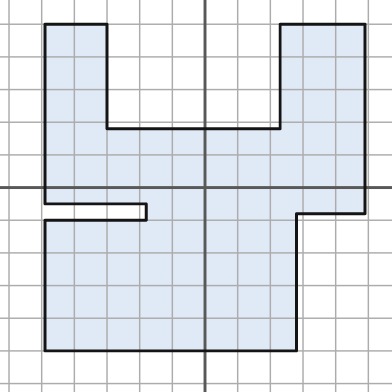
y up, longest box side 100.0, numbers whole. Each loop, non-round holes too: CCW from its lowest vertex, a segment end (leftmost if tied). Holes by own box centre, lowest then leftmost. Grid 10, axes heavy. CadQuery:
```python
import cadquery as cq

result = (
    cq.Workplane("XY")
    .moveTo(-49.0, -50.0)
    .lineTo(28.0, -50.0)
    .lineTo(28.0, -8.0)
    .lineTo(49.0, -8.0)
    .lineTo(49.0, 50.0)
    .lineTo(23.0, 50.0)
    .lineTo(23.0, 18.0)
    .lineTo(-30.0, 18.0)
    .lineTo(-30.0, 50.0)
    .lineTo(-49.0, 50.0)
    .lineTo(-49.0, -5.0)
    .lineTo(-18.0, -5.0)
    .lineTo(-18.0, -10.0)
    .lineTo(-49.0, -10.0)
    .close()
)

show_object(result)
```